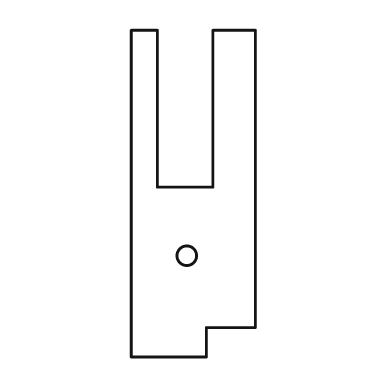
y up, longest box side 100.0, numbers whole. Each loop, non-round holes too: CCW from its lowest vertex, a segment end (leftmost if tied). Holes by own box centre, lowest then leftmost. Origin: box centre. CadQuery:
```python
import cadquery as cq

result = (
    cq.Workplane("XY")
    .moveTo(-19.0, -50.0)
    .lineTo(4.0, -50.0)
    .lineTo(4.0, -41.0)
    .lineTo(19.0, -41.0)
    .lineTo(19.0, 50.0)
    .lineTo(6.0, 50.0)
    .lineTo(6.0, 2.0)
    .lineTo(-11.0, 2.0)
    .lineTo(-11.0, 50.0)
    .lineTo(-19.0, 50.0)
    .close()
    .moveTo(-2.0, -19.0)
    .circle(3.0)
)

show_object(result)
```